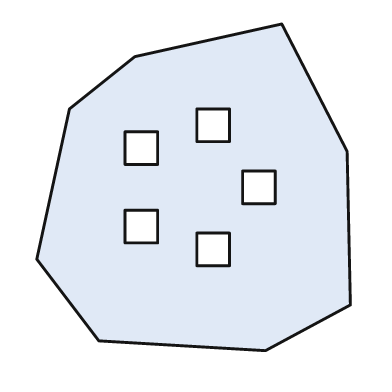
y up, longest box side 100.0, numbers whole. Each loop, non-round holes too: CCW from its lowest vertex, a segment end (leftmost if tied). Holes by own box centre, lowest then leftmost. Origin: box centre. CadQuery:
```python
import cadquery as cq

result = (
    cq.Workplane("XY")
    .moveTo(22.0, -50.0)
    .lineTo(48.0, -36.0)
    .lineTo(47.0, 11.0)
    .lineTo(27.0, 50.0)
    .lineTo(-18.0, 40.0)
    .lineTo(-38.0, 24.0)
    .lineTo(-48.0, -22.0)
    .lineTo(-29.0, -47.0)
    .close()
    .moveTo(1.0, -24.0)
    .lineTo(11.0, -24.0)
    .lineTo(11.0, -14.0)
    .lineTo(1.0, -14.0)
    .close()
    .moveTo(-21.0, -17.0)
    .lineTo(-11.0, -17.0)
    .lineTo(-11.0, -7.0)
    .lineTo(-21.0, -7.0)
    .close()
    .moveTo(15.0, -5.0)
    .lineTo(25.0, -5.0)
    .lineTo(25.0, 5.0)
    .lineTo(15.0, 5.0)
    .close()
    .moveTo(-21.0, 7.0)
    .lineTo(-11.0, 7.0)
    .lineTo(-11.0, 17.0)
    .lineTo(-21.0, 17.0)
    .close()
    .moveTo(1.0, 14.0)
    .lineTo(11.0, 14.0)
    .lineTo(11.0, 24.0)
    .lineTo(1.0, 24.0)
    .close()
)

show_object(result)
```